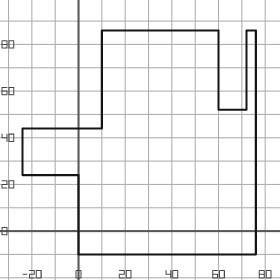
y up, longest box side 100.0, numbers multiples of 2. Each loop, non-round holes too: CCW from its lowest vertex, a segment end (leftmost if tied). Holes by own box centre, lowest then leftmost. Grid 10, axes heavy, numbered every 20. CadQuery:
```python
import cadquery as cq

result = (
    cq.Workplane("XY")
    .moveTo(0.0, -10.0)
    .lineTo(76.0, -10.0)
    .lineTo(76.0, 86.0)
    .lineTo(72.0, 86.0)
    .lineTo(72.0, 52.0)
    .lineTo(60.0, 52.0)
    .lineTo(60.0, 86.0)
    .lineTo(10.0, 86.0)
    .lineTo(10.0, 44.0)
    .lineTo(-24.0, 44.0)
    .lineTo(-24.0, 24.0)
    .lineTo(0.0, 24.0)
    .close()
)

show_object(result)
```